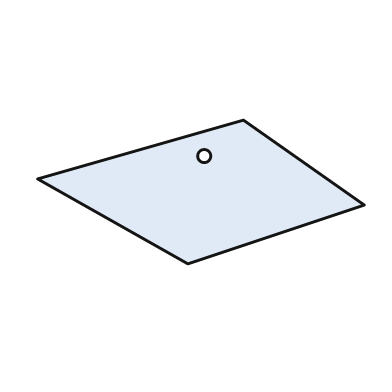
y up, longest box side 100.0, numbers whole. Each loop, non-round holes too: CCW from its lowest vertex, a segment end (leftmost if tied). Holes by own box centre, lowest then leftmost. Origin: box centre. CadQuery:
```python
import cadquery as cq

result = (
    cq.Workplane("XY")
    .moveTo(-4.0, -22.0)
    .lineTo(50.0, -4.0)
    .lineTo(13.0, 22.0)
    .lineTo(-50.0, 4.0)
    .close()
    .moveTo(1.0, 11.0)
    .circle(2.0)
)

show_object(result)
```